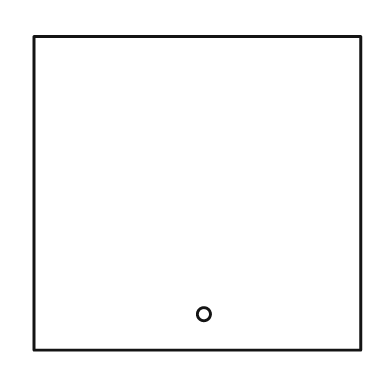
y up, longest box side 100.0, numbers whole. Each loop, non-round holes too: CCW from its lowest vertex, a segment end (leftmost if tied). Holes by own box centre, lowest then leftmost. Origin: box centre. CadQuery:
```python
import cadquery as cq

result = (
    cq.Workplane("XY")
    .moveTo(-50.0, -48.0)
    .lineTo(50.0, -48.0)
    .lineTo(50.0, 48.0)
    .lineTo(-50.0, 48.0)
    .close()
    .moveTo(2.0, -37.0)
    .circle(2.0)
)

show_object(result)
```